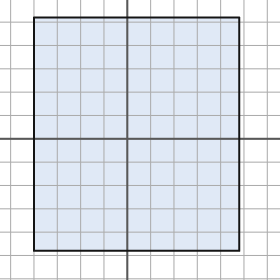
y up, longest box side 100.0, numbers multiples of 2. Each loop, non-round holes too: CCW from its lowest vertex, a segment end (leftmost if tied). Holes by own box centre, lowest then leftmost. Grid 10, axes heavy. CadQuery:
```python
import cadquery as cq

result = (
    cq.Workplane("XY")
    .moveTo(-40.0, -48.0)
    .lineTo(48.0, -48.0)
    .lineTo(48.0, 52.0)
    .lineTo(-40.0, 52.0)
    .close()
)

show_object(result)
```